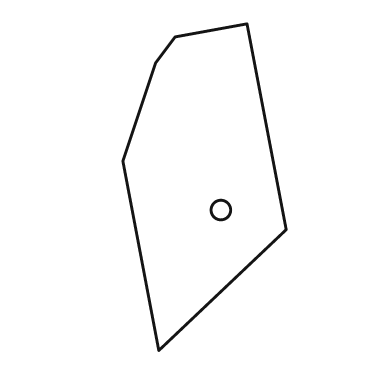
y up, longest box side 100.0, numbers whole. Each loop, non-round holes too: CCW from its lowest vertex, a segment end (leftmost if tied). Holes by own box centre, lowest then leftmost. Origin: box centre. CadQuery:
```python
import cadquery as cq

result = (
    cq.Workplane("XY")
    .moveTo(-14.0, -50.0)
    .lineTo(25.0, -13.0)
    .lineTo(13.0, 50.0)
    .lineTo(-9.0, 46.0)
    .lineTo(-15.0, 38.0)
    .lineTo(-25.0, 8.0)
    .close()
    .moveTo(5.0, -7.0)
    .circle(3.0)
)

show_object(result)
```